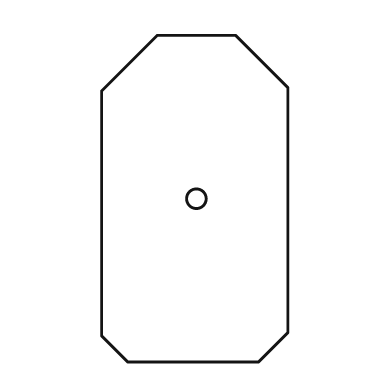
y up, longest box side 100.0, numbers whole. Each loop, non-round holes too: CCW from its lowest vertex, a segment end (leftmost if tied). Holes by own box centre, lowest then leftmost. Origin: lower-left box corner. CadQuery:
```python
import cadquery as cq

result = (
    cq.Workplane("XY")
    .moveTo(8.0, 0.0)
    .lineTo(48.0, 0.0)
    .lineTo(57.0, 9.0)
    .lineTo(57.0, 84.0)
    .lineTo(41.0, 100.0)
    .lineTo(17.0, 100.0)
    .lineTo(0.0, 83.0)
    .lineTo(0.0, 8.0)
    .close()
    .moveTo(29.0, 50.0)
    .circle(3.0)
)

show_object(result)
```